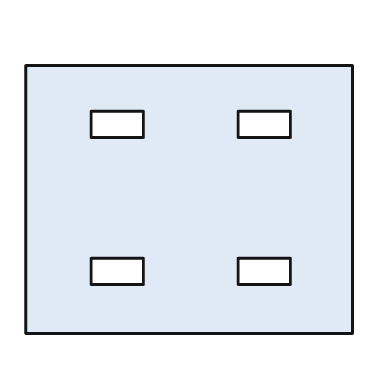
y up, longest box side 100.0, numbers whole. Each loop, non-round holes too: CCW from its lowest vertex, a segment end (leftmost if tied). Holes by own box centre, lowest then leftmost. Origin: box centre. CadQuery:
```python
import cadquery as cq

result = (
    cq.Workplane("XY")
    .moveTo(-50.0, -41.0)
    .lineTo(50.0, -41.0)
    .lineTo(50.0, 41.0)
    .lineTo(-50.0, 41.0)
    .close()
    .moveTo(-30.0, -26.0)
    .lineTo(-14.0, -26.0)
    .lineTo(-14.0, -18.0)
    .lineTo(-30.0, -18.0)
    .close()
    .moveTo(15.0, -26.0)
    .lineTo(31.0, -26.0)
    .lineTo(31.0, -18.0)
    .lineTo(15.0, -18.0)
    .close()
    .moveTo(-30.0, 19.0)
    .lineTo(-14.0, 19.0)
    .lineTo(-14.0, 27.0)
    .lineTo(-30.0, 27.0)
    .close()
    .moveTo(15.0, 19.0)
    .lineTo(31.0, 19.0)
    .lineTo(31.0, 27.0)
    .lineTo(15.0, 27.0)
    .close()
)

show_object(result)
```